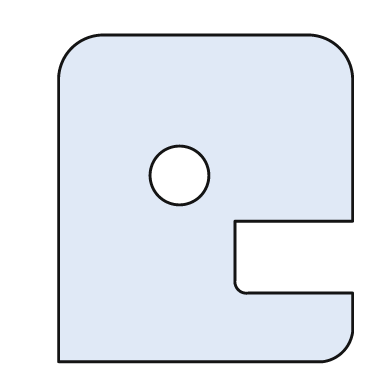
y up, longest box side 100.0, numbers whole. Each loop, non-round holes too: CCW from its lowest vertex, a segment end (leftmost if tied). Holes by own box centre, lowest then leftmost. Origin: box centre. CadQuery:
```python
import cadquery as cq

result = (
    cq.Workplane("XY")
    .moveTo(-45.0, -50.0)
    .lineTo(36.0, -50.0)
    .threePointArc((42.0, -47.0), (45.0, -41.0))
    .lineTo(45.0, -29.0)
    .lineTo(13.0, -29.0)
    .threePointArc((10.0, -28.0), (9.0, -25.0))
    .lineTo(9.0, -7.0)
    .lineTo(45.0, -7.0)
    .lineTo(45.0, 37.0)
    .threePointArc((41.0, 46.0), (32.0, 50.0))
    .lineTo(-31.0, 50.0)
    .threePointArc((-41.0, 46.0), (-45.0, 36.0))
    .close()
    .moveTo(-8.0, 7.0)
    .circle(9.0)
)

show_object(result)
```